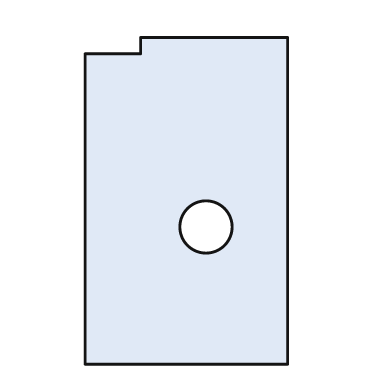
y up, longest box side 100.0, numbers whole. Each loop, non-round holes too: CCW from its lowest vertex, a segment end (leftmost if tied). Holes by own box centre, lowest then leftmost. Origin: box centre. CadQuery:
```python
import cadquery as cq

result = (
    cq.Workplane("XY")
    .moveTo(-31.0, -50.0)
    .lineTo(31.0, -50.0)
    .lineTo(31.0, 50.0)
    .lineTo(-14.0, 50.0)
    .lineTo(-14.0, 45.0)
    .lineTo(-31.0, 45.0)
    .close()
    .moveTo(6.0, -8.0)
    .circle(8.0)
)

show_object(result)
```